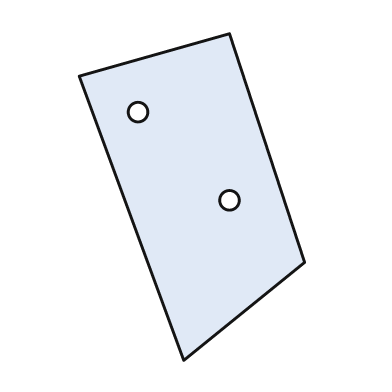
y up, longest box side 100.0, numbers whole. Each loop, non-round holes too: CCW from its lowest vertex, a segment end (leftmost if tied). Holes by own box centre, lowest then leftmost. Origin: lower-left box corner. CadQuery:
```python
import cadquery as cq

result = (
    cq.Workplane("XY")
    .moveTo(32.0, 0.0)
    .lineTo(69.0, 30.0)
    .lineTo(46.0, 100.0)
    .lineTo(0.0, 87.0)
    .close()
    .moveTo(46.0, 49.0)
    .circle(3.0)
    .moveTo(18.0, 76.0)
    .circle(3.0)
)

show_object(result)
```